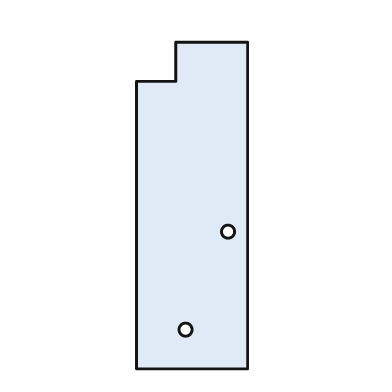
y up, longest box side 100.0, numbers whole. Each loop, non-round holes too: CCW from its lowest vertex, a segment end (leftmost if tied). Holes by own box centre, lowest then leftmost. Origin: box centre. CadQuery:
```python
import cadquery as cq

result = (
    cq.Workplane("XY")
    .moveTo(-17.0, -50.0)
    .lineTo(17.0, -50.0)
    .lineTo(17.0, 50.0)
    .lineTo(-5.0, 50.0)
    .lineTo(-5.0, 38.0)
    .lineTo(-17.0, 38.0)
    .close()
    .moveTo(-2.0, -38.0)
    .circle(2.0)
    .moveTo(11.0, -8.0)
    .circle(2.0)
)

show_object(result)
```